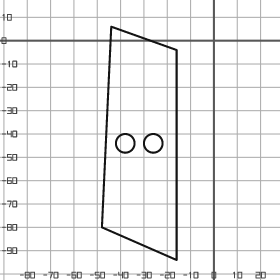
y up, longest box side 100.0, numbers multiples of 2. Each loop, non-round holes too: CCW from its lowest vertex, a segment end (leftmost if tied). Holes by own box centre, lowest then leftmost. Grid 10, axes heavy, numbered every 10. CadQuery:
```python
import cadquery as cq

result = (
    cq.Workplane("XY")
    .moveTo(-16.0, -94.0)
    .lineTo(-16.0, -4.0)
    .lineTo(-44.0, 6.0)
    .lineTo(-48.0, -80.0)
    .close()
    .moveTo(-38.0, -44.0)
    .circle(4.0)
    .moveTo(-26.0, -44.0)
    .circle(4.0)
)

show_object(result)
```